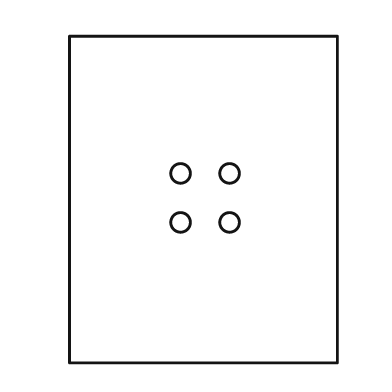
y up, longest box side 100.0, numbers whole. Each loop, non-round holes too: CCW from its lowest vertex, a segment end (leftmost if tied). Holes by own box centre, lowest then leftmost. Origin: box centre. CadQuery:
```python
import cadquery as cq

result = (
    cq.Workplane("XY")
    .moveTo(-41.0, -50.0)
    .lineTo(41.0, -50.0)
    .lineTo(41.0, 50.0)
    .lineTo(-41.0, 50.0)
    .close()
    .moveTo(-7.0, -7.0)
    .circle(3.0)
    .moveTo(8.0, -7.0)
    .circle(3.0)
    .moveTo(-7.0, 8.0)
    .circle(3.0)
    .moveTo(8.0, 8.0)
    .circle(3.0)
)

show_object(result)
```